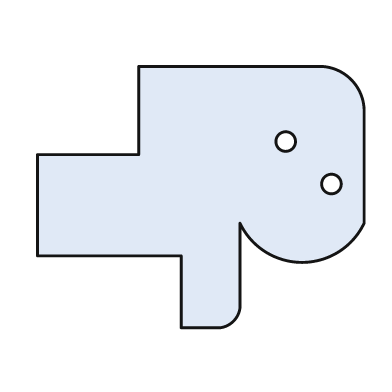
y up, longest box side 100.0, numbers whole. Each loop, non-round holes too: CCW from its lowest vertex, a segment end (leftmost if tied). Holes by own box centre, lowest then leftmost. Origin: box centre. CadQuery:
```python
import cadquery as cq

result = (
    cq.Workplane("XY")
    .moveTo(-6.0, -40.0)
    .lineTo(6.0, -40.0)
    .threePointArc((10.0, -38.0), (12.0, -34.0))
    .lineTo(12.0, -8.0)
    .threePointArc((31.0, -20.0), (50.0, -8.0))
    .lineTo(50.0, 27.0)
    .threePointArc((46.0, 36.0), (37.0, 40.0))
    .lineTo(-19.0, 40.0)
    .lineTo(-19.0, 13.0)
    .lineTo(-50.0, 13.0)
    .lineTo(-50.0, -18.0)
    .lineTo(-6.0, -18.0)
    .close()
    .moveTo(40.0, 4.0)
    .circle(3.0)
    .moveTo(26.0, 17.0)
    .circle(3.0)
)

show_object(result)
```